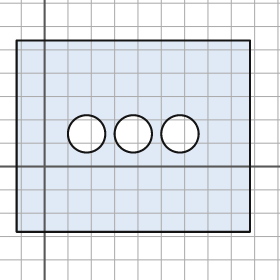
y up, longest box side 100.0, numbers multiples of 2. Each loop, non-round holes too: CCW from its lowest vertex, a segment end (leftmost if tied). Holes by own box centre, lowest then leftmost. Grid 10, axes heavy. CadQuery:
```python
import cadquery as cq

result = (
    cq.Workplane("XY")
    .moveTo(-12.0, -28.0)
    .lineTo(88.0, -28.0)
    .lineTo(88.0, 54.0)
    .lineTo(-12.0, 54.0)
    .close()
    .moveTo(18.0, 14.0)
    .circle(8.0)
    .moveTo(38.0, 14.0)
    .circle(8.0)
    .moveTo(58.0, 14.0)
    .circle(8.0)
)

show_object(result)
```